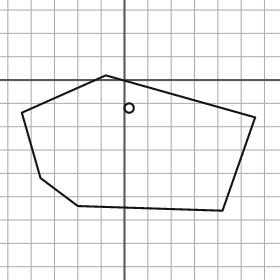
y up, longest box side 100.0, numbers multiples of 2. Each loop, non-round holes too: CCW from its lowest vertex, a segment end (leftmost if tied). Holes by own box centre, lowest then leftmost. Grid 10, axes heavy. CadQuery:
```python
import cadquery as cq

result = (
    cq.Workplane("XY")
    .moveTo(42.0, -56.0)
    .lineTo(56.0, -16.0)
    .lineTo(-8.0, 2.0)
    .lineTo(-44.0, -14.0)
    .lineTo(-36.0, -42.0)
    .lineTo(-20.0, -54.0)
    .close()
    .moveTo(2.0, -12.0)
    .circle(2.0)
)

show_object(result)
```